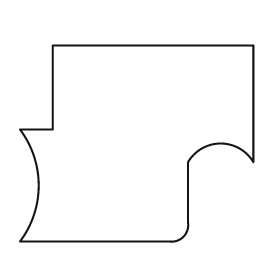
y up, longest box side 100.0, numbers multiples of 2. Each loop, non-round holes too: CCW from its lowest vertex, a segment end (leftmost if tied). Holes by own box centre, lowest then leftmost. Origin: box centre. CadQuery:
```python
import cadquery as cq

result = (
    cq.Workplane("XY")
    .moveTo(-50.0, -42.0)
    .lineTo(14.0, -42.0)
    .threePointArc((20.0, -40.0), (22.0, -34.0))
    .lineTo(22.0, -8.0)
    .threePointArc((36.0, 0.0), (50.0, -8.0))
    .lineTo(50.0, 42.0)
    .lineTo(-36.0, 42.0)
    .lineTo(-36.0, 6.0)
    .lineTo(-50.0, 6.0)
    .threePointArc((-42.0, -18.0), (-50.0, -42.0))
    .close()
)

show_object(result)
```